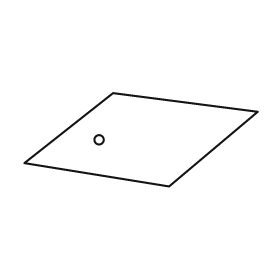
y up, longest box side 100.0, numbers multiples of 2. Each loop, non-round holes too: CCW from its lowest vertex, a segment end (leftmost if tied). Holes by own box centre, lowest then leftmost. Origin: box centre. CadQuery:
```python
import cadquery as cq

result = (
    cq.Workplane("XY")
    .moveTo(12.0, -20.0)
    .lineTo(50.0, 12.0)
    .lineTo(-12.0, 20.0)
    .lineTo(-50.0, -10.0)
    .close()
    .moveTo(-18.0, 0.0)
    .circle(2.0)
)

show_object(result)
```